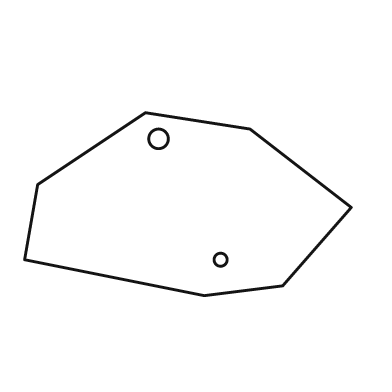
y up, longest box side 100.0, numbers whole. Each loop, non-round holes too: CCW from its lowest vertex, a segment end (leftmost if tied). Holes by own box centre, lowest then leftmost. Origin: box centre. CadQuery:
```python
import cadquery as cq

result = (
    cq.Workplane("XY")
    .moveTo(5.0, -28.0)
    .lineTo(29.0, -25.0)
    .lineTo(50.0, -1.0)
    .lineTo(19.0, 23.0)
    .lineTo(-13.0, 28.0)
    .lineTo(-46.0, 6.0)
    .lineTo(-50.0, -17.0)
    .close()
    .moveTo(10.0, -17.0)
    .circle(2.0)
    .moveTo(-9.0, 20.0)
    .circle(3.0)
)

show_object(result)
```